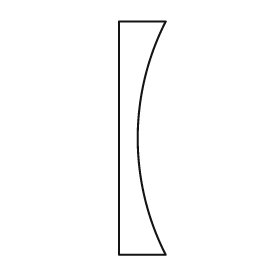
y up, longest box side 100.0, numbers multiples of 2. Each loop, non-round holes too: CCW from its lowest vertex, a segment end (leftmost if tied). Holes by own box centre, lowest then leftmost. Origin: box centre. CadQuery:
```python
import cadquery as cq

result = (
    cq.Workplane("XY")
    .moveTo(-10.0, -50.0)
    .lineTo(10.0, -50.0)
    .threePointArc((-2.0, 0.0), (10.0, 50.0))
    .lineTo(-10.0, 50.0)
    .close()
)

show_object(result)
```